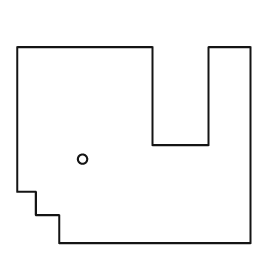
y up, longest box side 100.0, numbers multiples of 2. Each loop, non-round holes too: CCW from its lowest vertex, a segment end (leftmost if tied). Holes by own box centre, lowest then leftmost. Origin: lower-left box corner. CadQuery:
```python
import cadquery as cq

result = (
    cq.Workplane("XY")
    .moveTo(18.0, 0.0)
    .lineTo(100.0, 0.0)
    .lineTo(100.0, 84.0)
    .lineTo(82.0, 84.0)
    .lineTo(82.0, 42.0)
    .lineTo(58.0, 42.0)
    .lineTo(58.0, 84.0)
    .lineTo(0.0, 84.0)
    .lineTo(0.0, 22.0)
    .lineTo(8.0, 22.0)
    .lineTo(8.0, 12.0)
    .lineTo(18.0, 12.0)
    .close()
    .moveTo(28.0, 36.0)
    .circle(2.0)
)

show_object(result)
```